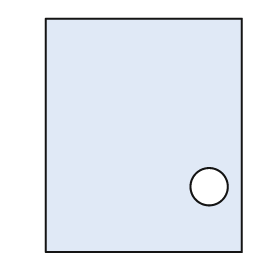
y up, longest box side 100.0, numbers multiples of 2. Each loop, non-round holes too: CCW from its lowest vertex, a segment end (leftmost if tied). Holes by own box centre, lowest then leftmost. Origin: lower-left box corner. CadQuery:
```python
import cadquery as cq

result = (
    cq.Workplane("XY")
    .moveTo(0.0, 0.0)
    .lineTo(84.0, 0.0)
    .lineTo(84.0, 100.0)
    .lineTo(0.0, 100.0)
    .close()
    .moveTo(70.0, 28.0)
    .circle(8.0)
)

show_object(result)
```